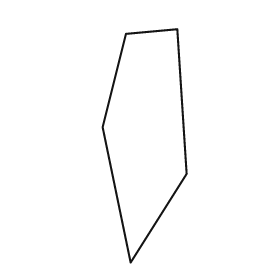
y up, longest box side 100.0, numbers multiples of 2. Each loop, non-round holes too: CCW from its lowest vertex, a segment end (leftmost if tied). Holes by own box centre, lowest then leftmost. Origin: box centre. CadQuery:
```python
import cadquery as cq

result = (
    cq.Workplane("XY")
    .moveTo(-6.0, -50.0)
    .lineTo(18.0, -12.0)
    .lineTo(14.0, 50.0)
    .lineTo(-8.0, 48.0)
    .lineTo(-18.0, 8.0)
    .close()
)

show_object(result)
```